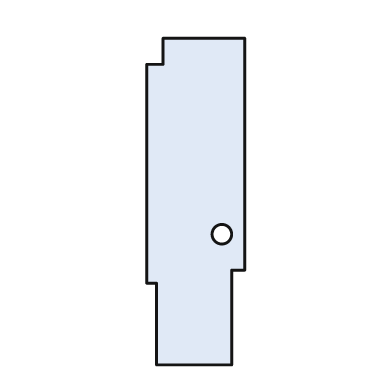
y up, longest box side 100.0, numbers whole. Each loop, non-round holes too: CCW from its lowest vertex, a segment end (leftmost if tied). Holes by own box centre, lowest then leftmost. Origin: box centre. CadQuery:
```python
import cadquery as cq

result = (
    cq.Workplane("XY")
    .moveTo(-12.0, -50.0)
    .lineTo(11.0, -50.0)
    .lineTo(11.0, -21.0)
    .lineTo(15.0, -21.0)
    .lineTo(15.0, 50.0)
    .lineTo(-10.0, 50.0)
    .lineTo(-10.0, 42.0)
    .lineTo(-15.0, 42.0)
    .lineTo(-15.0, -25.0)
    .lineTo(-12.0, -25.0)
    .close()
    .moveTo(8.0, -10.0)
    .circle(3.0)
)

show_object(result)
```